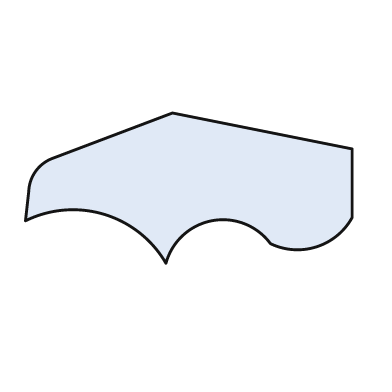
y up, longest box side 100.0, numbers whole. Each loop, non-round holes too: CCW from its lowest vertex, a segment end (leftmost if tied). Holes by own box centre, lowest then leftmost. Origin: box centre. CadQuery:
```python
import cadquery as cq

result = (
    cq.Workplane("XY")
    .moveTo(-7.0, -23.0)
    .threePointArc((7.0, -10.0), (25.0, -17.0))
    .threePointArc((39.0, -18.0), (50.0, -9.0))
    .lineTo(50.0, 12.0)
    .lineTo(-5.0, 23.0)
    .lineTo(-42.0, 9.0)
    .threePointArc((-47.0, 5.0), (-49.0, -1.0))
    .lineTo(-50.0, -10.0)
    .threePointArc((-26.0, -8.0), (-7.0, -23.0))
    .close()
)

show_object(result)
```